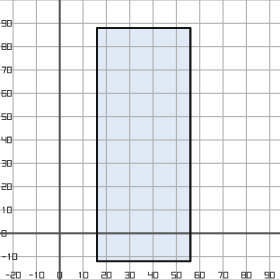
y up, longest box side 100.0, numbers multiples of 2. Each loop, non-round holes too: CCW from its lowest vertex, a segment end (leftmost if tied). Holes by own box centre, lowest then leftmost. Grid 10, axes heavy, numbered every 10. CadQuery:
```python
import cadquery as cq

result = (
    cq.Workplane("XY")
    .moveTo(16.0, -12.0)
    .lineTo(56.0, -12.0)
    .lineTo(56.0, 88.0)
    .lineTo(16.0, 88.0)
    .close()
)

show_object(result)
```